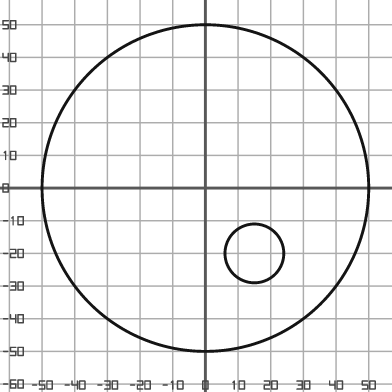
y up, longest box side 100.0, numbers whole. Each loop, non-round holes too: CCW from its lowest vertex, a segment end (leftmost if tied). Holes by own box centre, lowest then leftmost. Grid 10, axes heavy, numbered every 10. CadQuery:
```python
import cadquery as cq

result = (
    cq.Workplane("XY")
    .moveTo(0.0, 0.0)
    .circle(50.0)
    .moveTo(15.0, -20.0)
    .circle(9.0)
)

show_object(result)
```